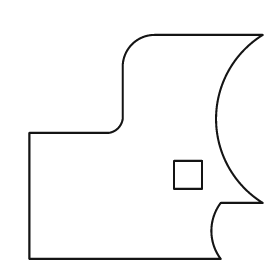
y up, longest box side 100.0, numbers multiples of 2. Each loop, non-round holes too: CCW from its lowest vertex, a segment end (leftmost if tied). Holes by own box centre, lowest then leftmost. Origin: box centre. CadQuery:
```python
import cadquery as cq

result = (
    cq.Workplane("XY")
    .moveTo(-50.0, -48.0)
    .lineTo(32.0, -48.0)
    .threePointArc((28.0, -36.0), (32.0, -24.0))
    .lineTo(50.0, -24.0)
    .threePointArc((30.0, 12.0), (50.0, 48.0))
    .lineTo(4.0, 48.0)
    .threePointArc((-6.0, 44.0), (-10.0, 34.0))
    .lineTo(-10.0, 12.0)
    .threePointArc((-12.0, 8.0), (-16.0, 6.0))
    .lineTo(-50.0, 6.0)
    .close()
    .moveTo(12.0, -18.0)
    .lineTo(24.0, -18.0)
    .lineTo(24.0, -6.0)
    .lineTo(12.0, -6.0)
    .close()
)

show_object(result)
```